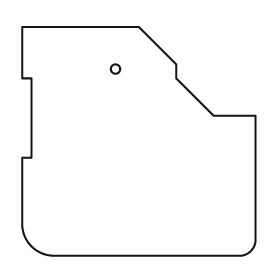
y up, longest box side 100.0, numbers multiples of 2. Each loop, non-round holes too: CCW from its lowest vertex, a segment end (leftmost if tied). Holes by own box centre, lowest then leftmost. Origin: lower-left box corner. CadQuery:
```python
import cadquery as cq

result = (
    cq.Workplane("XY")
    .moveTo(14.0, 0.0)
    .lineTo(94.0, 0.0)
    .threePointArc((98.0, 2.0), (100.0, 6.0))
    .lineTo(100.0, 60.0)
    .lineTo(82.0, 60.0)
    .lineTo(66.0, 76.0)
    .lineTo(66.0, 82.0)
    .lineTo(50.0, 98.0)
    .lineTo(0.0, 98.0)
    .lineTo(0.0, 76.0)
    .lineTo(4.0, 76.0)
    .lineTo(4.0, 42.0)
    .lineTo(0.0, 42.0)
    .lineTo(0.0, 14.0)
    .threePointArc((4.0, 4.0), (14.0, 0.0))
    .close()
    .moveTo(40.0, 80.0)
    .circle(2.0)
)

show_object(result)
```